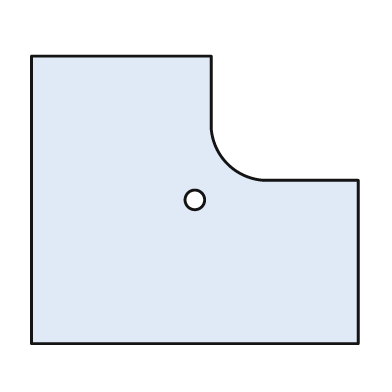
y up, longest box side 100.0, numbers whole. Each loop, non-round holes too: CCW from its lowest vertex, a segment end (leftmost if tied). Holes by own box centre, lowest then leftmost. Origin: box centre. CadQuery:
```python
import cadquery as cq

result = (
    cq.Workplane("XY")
    .moveTo(-50.0, -44.0)
    .lineTo(50.0, -44.0)
    .lineTo(50.0, 6.0)
    .lineTo(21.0, 6.0)
    .threePointArc((10.0, 11.0), (5.0, 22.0))
    .lineTo(5.0, 44.0)
    .lineTo(-50.0, 44.0)
    .close()
    .moveTo(0.0, 0.0)
    .circle(3.0)
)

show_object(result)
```